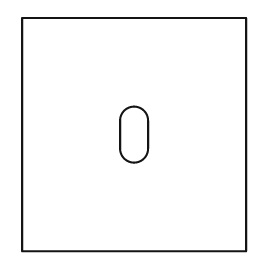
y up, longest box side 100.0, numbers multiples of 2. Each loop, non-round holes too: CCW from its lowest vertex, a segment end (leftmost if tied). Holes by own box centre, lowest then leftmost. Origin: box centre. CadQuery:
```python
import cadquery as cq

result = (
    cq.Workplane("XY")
    .moveTo(-48.0, -50.0)
    .lineTo(48.0, -50.0)
    .lineTo(48.0, 50.0)
    .lineTo(-48.0, 50.0)
    .close()
    .moveTo(-6.0, -6.0)
    .threePointArc((0.0, -12.0), (6.0, -6.0))
    .lineTo(6.0, 6.0)
    .threePointArc((0.0, 12.0), (-6.0, 6.0))
    .close()
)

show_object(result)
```